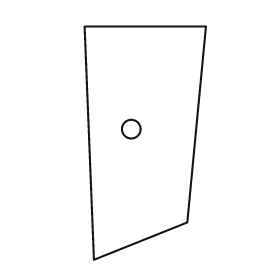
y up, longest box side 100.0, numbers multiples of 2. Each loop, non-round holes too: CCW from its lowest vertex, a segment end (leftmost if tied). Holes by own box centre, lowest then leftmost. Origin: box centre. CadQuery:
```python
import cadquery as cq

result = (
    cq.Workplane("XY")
    .moveTo(-22.0, -50.0)
    .lineTo(18.0, -34.0)
    .lineTo(26.0, 50.0)
    .lineTo(-26.0, 50.0)
    .close()
    .moveTo(-6.0, 6.0)
    .circle(4.0)
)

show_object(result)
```